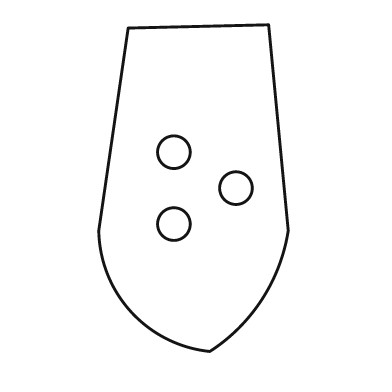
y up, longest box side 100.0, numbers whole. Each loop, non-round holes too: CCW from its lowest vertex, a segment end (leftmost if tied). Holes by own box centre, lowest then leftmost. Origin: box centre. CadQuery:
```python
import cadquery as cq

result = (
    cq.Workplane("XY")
    .moveTo(5.0, -50.0)
    .threePointArc((21.0, -34.0), (29.0, -13.0))
    .lineTo(23.0, 50.0)
    .lineTo(-20.0, 49.0)
    .lineTo(-29.0, -13.0)
    .threePointArc((-19.0, -38.0), (5.0, -50.0))
    .close()
    .moveTo(-6.0, -11.0)
    .circle(5.0)
    .moveTo(13.0, 0.0)
    .circle(5.0)
    .moveTo(-6.0, 11.0)
    .circle(5.0)
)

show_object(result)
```